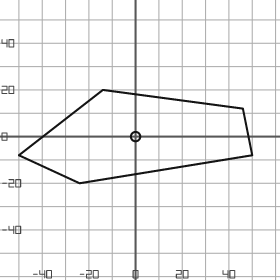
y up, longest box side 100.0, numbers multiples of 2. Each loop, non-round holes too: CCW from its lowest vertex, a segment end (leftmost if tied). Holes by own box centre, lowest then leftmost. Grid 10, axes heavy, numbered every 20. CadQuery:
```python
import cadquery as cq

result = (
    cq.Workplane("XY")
    .moveTo(-24.0, -20.0)
    .lineTo(50.0, -8.0)
    .lineTo(46.0, 12.0)
    .lineTo(-14.0, 20.0)
    .lineTo(-50.0, -8.0)
    .close()
    .moveTo(0.0, 0.0)
    .circle(2.0)
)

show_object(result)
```